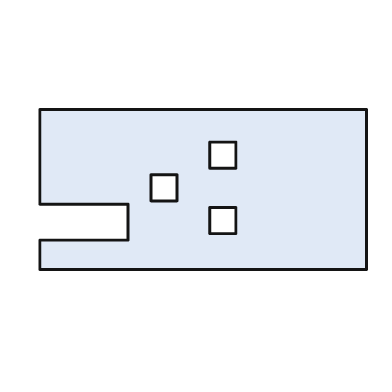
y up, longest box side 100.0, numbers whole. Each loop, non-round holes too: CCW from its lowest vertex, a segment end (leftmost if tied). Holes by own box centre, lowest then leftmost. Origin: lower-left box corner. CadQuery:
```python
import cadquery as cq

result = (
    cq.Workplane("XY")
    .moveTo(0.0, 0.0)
    .lineTo(100.0, 0.0)
    .lineTo(100.0, 49.0)
    .lineTo(0.0, 49.0)
    .lineTo(0.0, 20.0)
    .lineTo(27.0, 20.0)
    .lineTo(27.0, 9.0)
    .lineTo(0.0, 9.0)
    .close()
    .moveTo(52.0, 11.0)
    .lineTo(60.0, 11.0)
    .lineTo(60.0, 19.0)
    .lineTo(52.0, 19.0)
    .close()
    .moveTo(34.0, 21.0)
    .lineTo(42.0, 21.0)
    .lineTo(42.0, 29.0)
    .lineTo(34.0, 29.0)
    .close()
    .moveTo(52.0, 31.0)
    .lineTo(60.0, 31.0)
    .lineTo(60.0, 39.0)
    .lineTo(52.0, 39.0)
    .close()
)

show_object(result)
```